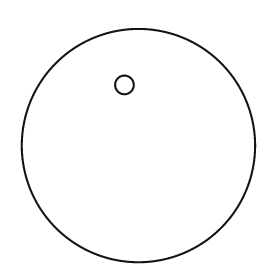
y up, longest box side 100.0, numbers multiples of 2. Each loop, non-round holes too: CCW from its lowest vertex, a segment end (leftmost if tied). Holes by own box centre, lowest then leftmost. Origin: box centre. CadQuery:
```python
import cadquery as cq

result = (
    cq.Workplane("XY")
    .moveTo(0.0, 0.0)
    .circle(50.0)
    .moveTo(-6.0, 26.0)
    .circle(4.0)
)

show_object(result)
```